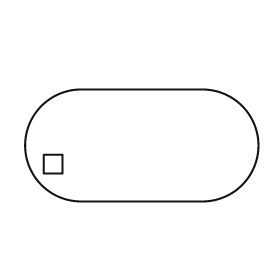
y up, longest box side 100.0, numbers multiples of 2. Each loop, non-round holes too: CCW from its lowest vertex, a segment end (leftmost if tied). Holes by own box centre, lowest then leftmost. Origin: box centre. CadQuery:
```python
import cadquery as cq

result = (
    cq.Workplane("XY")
    .moveTo(-26.0, -24.0)
    .lineTo(26.0, -24.0)
    .threePointArc((50.0, 0.0), (26.0, 24.0))
    .lineTo(-26.0, 24.0)
    .threePointArc((-50.0, 0.0), (-26.0, -24.0))
    .close()
    .moveTo(-42.0, -12.0)
    .lineTo(-34.0, -12.0)
    .lineTo(-34.0, -4.0)
    .lineTo(-42.0, -4.0)
    .close()
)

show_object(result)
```